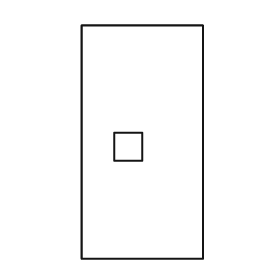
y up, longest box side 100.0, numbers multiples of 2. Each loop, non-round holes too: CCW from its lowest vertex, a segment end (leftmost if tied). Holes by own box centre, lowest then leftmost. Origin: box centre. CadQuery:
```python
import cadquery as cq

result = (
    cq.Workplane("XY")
    .moveTo(-26.0, -50.0)
    .lineTo(26.0, -50.0)
    .lineTo(26.0, 50.0)
    .lineTo(-26.0, 50.0)
    .close()
    .moveTo(-12.0, -8.0)
    .lineTo(0.0, -8.0)
    .lineTo(0.0, 4.0)
    .lineTo(-12.0, 4.0)
    .close()
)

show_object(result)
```